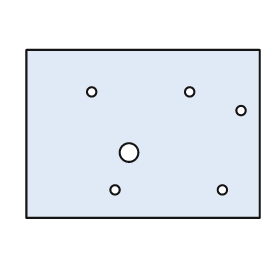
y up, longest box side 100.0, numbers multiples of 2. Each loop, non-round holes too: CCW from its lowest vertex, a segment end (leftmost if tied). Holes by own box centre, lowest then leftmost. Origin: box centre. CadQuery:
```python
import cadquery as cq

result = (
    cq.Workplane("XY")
    .moveTo(-50.0, -36.0)
    .lineTo(50.0, -36.0)
    .lineTo(50.0, 36.0)
    .lineTo(-50.0, 36.0)
    .close()
    .moveTo(-12.0, -24.0)
    .circle(2.0)
    .moveTo(34.0, -24.0)
    .circle(2.0)
    .moveTo(-6.0, -8.0)
    .circle(4.0)
    .moveTo(42.0, 10.0)
    .circle(2.0)
    .moveTo(-22.0, 18.0)
    .circle(2.0)
    .moveTo(20.0, 18.0)
    .circle(2.0)
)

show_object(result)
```